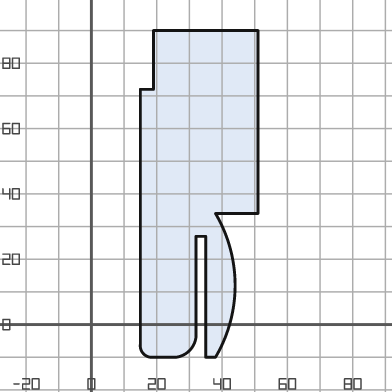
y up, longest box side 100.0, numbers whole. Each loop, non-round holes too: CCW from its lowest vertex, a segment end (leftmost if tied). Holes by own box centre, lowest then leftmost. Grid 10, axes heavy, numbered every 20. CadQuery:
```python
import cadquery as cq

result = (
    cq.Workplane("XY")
    .moveTo(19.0, -10.0)
    .lineTo(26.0, -10.0)
    .threePointArc((30.0, -8.0), (32.0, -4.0))
    .lineTo(32.0, 27.0)
    .lineTo(35.0, 27.0)
    .lineTo(35.0, -10.0)
    .lineTo(38.0, -10.0)
    .threePointArc((44.0, 12.0), (38.0, 34.0))
    .lineTo(51.0, 34.0)
    .lineTo(51.0, 90.0)
    .lineTo(19.0, 90.0)
    .lineTo(19.0, 72.0)
    .lineTo(15.0, 72.0)
    .lineTo(15.0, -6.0)
    .threePointArc((16.0, -9.0), (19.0, -10.0))
    .close()
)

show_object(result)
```